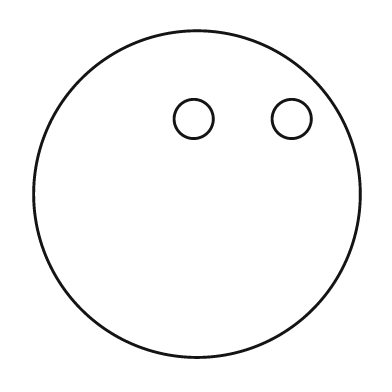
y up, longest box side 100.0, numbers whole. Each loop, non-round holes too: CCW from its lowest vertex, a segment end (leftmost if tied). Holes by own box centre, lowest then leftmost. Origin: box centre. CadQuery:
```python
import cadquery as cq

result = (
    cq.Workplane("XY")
    .moveTo(0.0, 0.0)
    .circle(50.0)
    .moveTo(-1.0, 23.0)
    .circle(6.0)
    .moveTo(29.0, 23.0)
    .circle(6.0)
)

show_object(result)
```